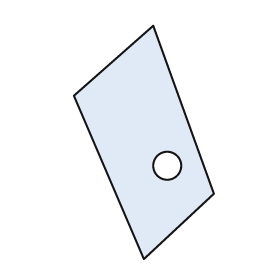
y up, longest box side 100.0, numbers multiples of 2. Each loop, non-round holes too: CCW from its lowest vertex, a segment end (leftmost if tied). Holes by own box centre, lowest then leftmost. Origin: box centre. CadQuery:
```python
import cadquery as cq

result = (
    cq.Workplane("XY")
    .moveTo(0.0, -50.0)
    .lineTo(30.0, -22.0)
    .lineTo(4.0, 50.0)
    .lineTo(-30.0, 20.0)
    .close()
    .moveTo(10.0, -10.0)
    .circle(6.0)
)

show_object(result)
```